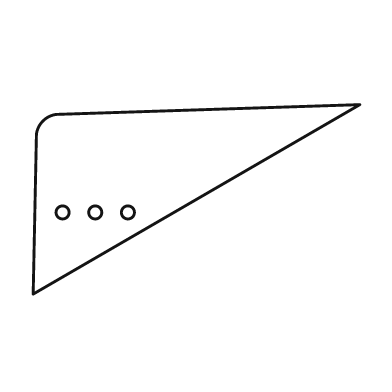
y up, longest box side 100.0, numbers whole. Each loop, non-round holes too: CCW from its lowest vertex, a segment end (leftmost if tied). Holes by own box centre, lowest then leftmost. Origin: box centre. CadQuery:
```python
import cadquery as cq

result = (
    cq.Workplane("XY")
    .moveTo(-50.0, -29.0)
    .lineTo(50.0, 29.0)
    .lineTo(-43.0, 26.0)
    .threePointArc((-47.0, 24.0), (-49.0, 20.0))
    .close()
    .moveTo(-41.0, -4.0)
    .circle(2.0)
    .moveTo(-31.0, -4.0)
    .circle(2.0)
    .moveTo(-21.0, -4.0)
    .circle(2.0)
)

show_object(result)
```